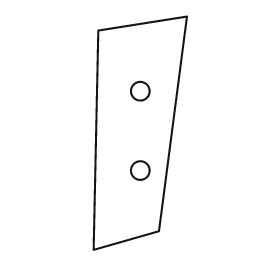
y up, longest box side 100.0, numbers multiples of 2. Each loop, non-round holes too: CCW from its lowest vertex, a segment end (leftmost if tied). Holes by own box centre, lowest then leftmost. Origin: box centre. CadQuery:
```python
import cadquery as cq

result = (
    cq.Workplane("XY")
    .moveTo(-20.0, -50.0)
    .lineTo(8.0, -42.0)
    .lineTo(20.0, 50.0)
    .lineTo(-18.0, 44.0)
    .close()
    .moveTo(0.0, -16.0)
    .circle(4.0)
    .moveTo(0.0, 18.0)
    .circle(4.0)
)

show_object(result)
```